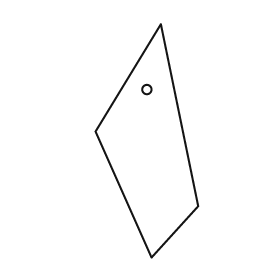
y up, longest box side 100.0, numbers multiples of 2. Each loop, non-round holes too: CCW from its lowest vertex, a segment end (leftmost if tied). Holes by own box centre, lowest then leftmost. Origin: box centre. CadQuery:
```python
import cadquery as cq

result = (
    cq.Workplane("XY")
    .moveTo(2.0, -50.0)
    .lineTo(22.0, -28.0)
    .lineTo(6.0, 50.0)
    .lineTo(-22.0, 4.0)
    .close()
    .moveTo(0.0, 22.0)
    .circle(2.0)
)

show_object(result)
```